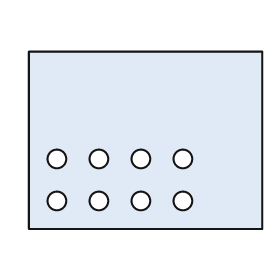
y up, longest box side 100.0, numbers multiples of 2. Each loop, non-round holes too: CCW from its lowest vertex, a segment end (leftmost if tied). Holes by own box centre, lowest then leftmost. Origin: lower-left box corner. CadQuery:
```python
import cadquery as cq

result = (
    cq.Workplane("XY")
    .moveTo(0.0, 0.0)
    .lineTo(100.0, 0.0)
    .lineTo(100.0, 76.0)
    .lineTo(0.0, 76.0)
    .close()
    .moveTo(12.0, 12.0)
    .circle(4.0)
    .moveTo(30.0, 12.0)
    .circle(4.0)
    .moveTo(48.0, 12.0)
    .circle(4.0)
    .moveTo(66.0, 12.0)
    .circle(4.0)
    .moveTo(12.0, 30.0)
    .circle(4.0)
    .moveTo(30.0, 30.0)
    .circle(4.0)
    .moveTo(48.0, 30.0)
    .circle(4.0)
    .moveTo(66.0, 30.0)
    .circle(4.0)
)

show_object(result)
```